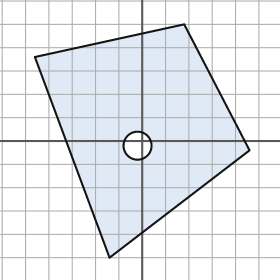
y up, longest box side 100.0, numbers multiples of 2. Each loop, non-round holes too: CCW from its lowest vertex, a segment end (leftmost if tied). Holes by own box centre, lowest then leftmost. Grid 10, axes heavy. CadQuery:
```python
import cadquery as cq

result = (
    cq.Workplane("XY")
    .moveTo(-14.0, -50.0)
    .lineTo(46.0, -4.0)
    .lineTo(18.0, 50.0)
    .lineTo(-46.0, 36.0)
    .close()
    .moveTo(-2.0, -2.0)
    .circle(6.0)
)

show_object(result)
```